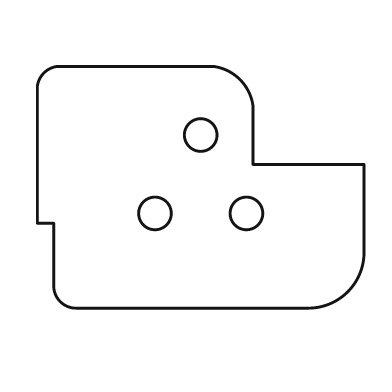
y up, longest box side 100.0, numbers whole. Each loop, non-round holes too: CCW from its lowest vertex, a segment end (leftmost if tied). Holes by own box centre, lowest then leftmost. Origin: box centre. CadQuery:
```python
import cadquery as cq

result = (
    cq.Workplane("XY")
    .moveTo(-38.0, -37.0)
    .lineTo(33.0, -37.0)
    .threePointArc((45.0, -32.0), (50.0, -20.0))
    .lineTo(50.0, 7.0)
    .lineTo(16.0, 7.0)
    .lineTo(16.0, 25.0)
    .threePointArc((12.0, 33.0), (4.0, 37.0))
    .lineTo(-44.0, 37.0)
    .threePointArc((-48.0, 35.0), (-50.0, 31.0))
    .lineTo(-50.0, -11.0)
    .lineTo(-45.0, -11.0)
    .lineTo(-45.0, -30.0)
    .threePointArc((-43.0, -35.0), (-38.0, -37.0))
    .close()
    .moveTo(-14.0, -8.0)
    .circle(5.0)
    .moveTo(14.0, -8.0)
    .circle(5.0)
    .moveTo(0.0, 16.0)
    .circle(5.0)
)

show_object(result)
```